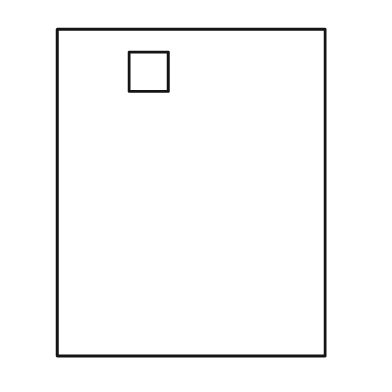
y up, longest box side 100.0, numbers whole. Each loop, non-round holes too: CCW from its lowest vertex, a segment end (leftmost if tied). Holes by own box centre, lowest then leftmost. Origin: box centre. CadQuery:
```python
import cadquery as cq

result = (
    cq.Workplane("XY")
    .moveTo(-41.0, -50.0)
    .lineTo(41.0, -50.0)
    .lineTo(41.0, 50.0)
    .lineTo(-41.0, 50.0)
    .close()
    .moveTo(-19.0, 31.0)
    .lineTo(-7.0, 31.0)
    .lineTo(-7.0, 43.0)
    .lineTo(-19.0, 43.0)
    .close()
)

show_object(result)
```